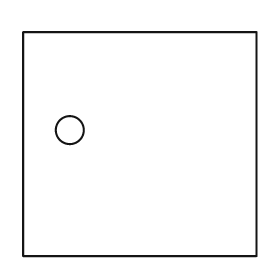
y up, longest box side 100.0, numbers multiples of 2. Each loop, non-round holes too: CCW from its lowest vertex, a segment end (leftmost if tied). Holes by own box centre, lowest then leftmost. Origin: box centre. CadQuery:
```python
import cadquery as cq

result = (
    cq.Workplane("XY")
    .moveTo(-50.0, -48.0)
    .lineTo(50.0, -48.0)
    .lineTo(50.0, 48.0)
    .lineTo(-50.0, 48.0)
    .close()
    .moveTo(-30.0, 6.0)
    .circle(6.0)
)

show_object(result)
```